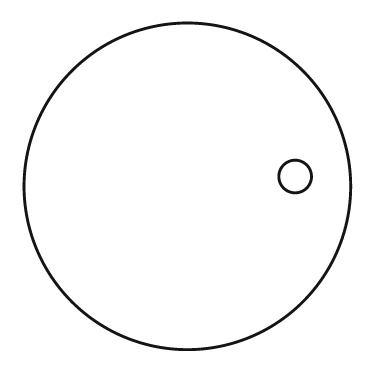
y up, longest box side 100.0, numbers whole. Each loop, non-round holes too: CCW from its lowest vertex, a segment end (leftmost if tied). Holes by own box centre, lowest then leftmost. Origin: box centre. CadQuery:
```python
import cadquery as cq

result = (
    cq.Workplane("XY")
    .moveTo(0.0, 0.0)
    .circle(50.0)
    .moveTo(33.0, 3.0)
    .circle(5.0)
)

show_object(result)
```